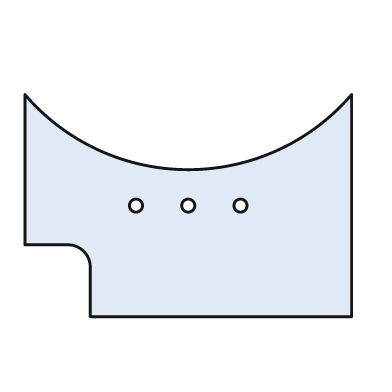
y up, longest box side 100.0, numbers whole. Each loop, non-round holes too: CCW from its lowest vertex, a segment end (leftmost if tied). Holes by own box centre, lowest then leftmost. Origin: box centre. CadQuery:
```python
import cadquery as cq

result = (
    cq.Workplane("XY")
    .moveTo(-30.0, -34.0)
    .lineTo(50.0, -34.0)
    .lineTo(50.0, 34.0)
    .threePointArc((0.0, 11.0), (-50.0, 34.0))
    .lineTo(-50.0, -12.0)
    .lineTo(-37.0, -12.0)
    .threePointArc((-32.0, -14.0), (-30.0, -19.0))
    .close()
    .moveTo(-16.0, 0.0)
    .circle(2.0)
    .moveTo(0.0, 0.0)
    .circle(2.0)
    .moveTo(16.0, 0.0)
    .circle(2.0)
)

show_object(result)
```